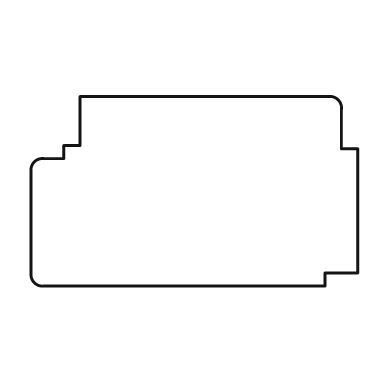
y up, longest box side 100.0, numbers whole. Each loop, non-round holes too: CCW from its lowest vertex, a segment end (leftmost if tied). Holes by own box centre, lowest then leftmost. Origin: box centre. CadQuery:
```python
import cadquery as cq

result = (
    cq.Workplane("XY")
    .moveTo(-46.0, -29.0)
    .lineTo(40.0, -29.0)
    .lineTo(40.0, -25.0)
    .lineTo(50.0, -25.0)
    .lineTo(50.0, 13.0)
    .lineTo(45.0, 13.0)
    .lineTo(45.0, 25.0)
    .threePointArc((44.0, 28.0), (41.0, 29.0))
    .lineTo(-35.0, 29.0)
    .lineTo(-35.0, 14.0)
    .lineTo(-40.0, 14.0)
    .lineTo(-40.0, 10.0)
    .lineTo(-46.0, 10.0)
    .threePointArc((-49.0, 9.0), (-50.0, 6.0))
    .lineTo(-50.0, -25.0)
    .threePointArc((-49.0, -28.0), (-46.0, -29.0))
    .close()
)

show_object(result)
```